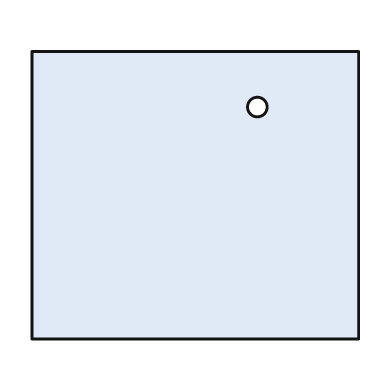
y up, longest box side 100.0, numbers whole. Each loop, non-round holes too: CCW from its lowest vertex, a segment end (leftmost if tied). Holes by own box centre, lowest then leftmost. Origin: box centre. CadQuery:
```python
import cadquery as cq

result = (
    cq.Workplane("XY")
    .moveTo(-50.0, -44.0)
    .lineTo(50.0, -44.0)
    .lineTo(50.0, 44.0)
    .lineTo(-50.0, 44.0)
    .close()
    .moveTo(19.0, 27.0)
    .circle(3.0)
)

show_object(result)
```